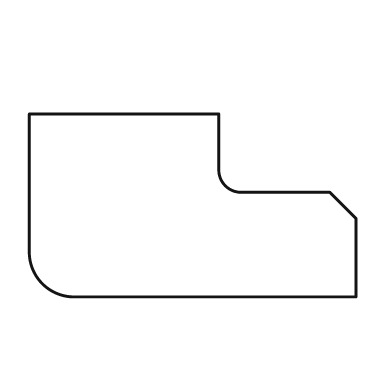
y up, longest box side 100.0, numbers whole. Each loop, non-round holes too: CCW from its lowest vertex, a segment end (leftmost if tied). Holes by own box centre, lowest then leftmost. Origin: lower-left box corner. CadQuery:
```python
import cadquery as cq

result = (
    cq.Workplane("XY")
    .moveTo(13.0, 0.0)
    .lineTo(100.0, 0.0)
    .lineTo(100.0, 24.0)
    .lineTo(92.0, 32.0)
    .lineTo(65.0, 32.0)
    .threePointArc((60.0, 34.0), (58.0, 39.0))
    .lineTo(58.0, 56.0)
    .lineTo(0.0, 56.0)
    .lineTo(0.0, 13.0)
    .threePointArc((4.0, 4.0), (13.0, 0.0))
    .close()
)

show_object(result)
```